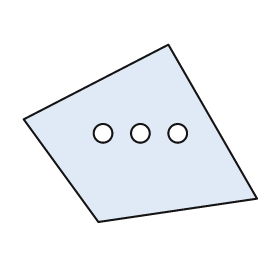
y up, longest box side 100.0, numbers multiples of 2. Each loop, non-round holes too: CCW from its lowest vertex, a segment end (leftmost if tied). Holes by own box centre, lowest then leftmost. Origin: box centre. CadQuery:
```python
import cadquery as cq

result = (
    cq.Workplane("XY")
    .moveTo(-18.0, -38.0)
    .lineTo(50.0, -28.0)
    .lineTo(12.0, 38.0)
    .lineTo(-50.0, 6.0)
    .close()
    .moveTo(-16.0, 0.0)
    .circle(4.0)
    .moveTo(0.0, 0.0)
    .circle(4.0)
    .moveTo(16.0, 0.0)
    .circle(4.0)
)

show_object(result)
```